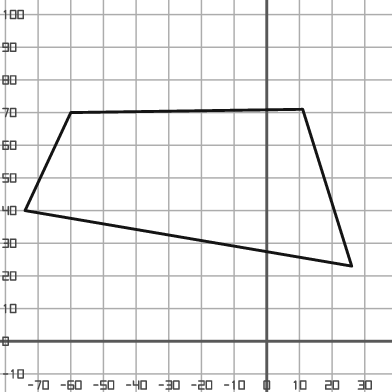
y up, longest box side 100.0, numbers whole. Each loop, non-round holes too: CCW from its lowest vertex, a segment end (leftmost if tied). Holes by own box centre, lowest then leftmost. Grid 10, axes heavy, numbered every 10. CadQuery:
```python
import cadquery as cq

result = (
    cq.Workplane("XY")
    .moveTo(26.0, 23.0)
    .lineTo(11.0, 71.0)
    .lineTo(-60.0, 70.0)
    .lineTo(-74.0, 40.0)
    .close()
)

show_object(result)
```